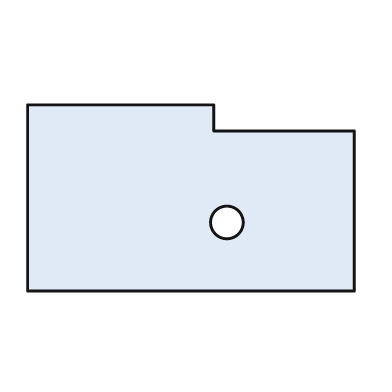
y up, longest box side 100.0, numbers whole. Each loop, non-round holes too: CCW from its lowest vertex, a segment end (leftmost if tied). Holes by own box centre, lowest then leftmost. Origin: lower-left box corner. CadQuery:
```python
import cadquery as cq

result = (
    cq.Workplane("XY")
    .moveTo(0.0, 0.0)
    .lineTo(100.0, 0.0)
    .lineTo(100.0, 49.0)
    .lineTo(57.0, 49.0)
    .lineTo(57.0, 57.0)
    .lineTo(0.0, 57.0)
    .close()
    .moveTo(61.0, 21.0)
    .circle(5.0)
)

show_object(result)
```